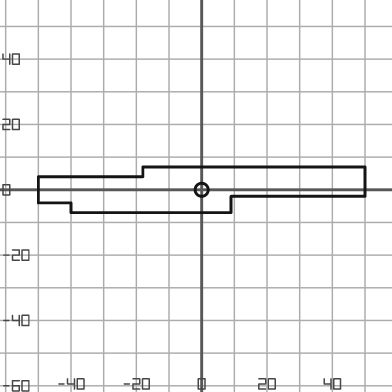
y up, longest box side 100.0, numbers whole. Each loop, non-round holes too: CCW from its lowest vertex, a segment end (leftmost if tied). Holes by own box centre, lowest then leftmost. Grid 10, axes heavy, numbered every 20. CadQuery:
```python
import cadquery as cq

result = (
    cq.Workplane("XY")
    .moveTo(-40.0, -7.0)
    .lineTo(9.0, -7.0)
    .lineTo(9.0, -2.0)
    .lineTo(50.0, -2.0)
    .lineTo(50.0, 7.0)
    .lineTo(-18.0, 7.0)
    .lineTo(-18.0, 4.0)
    .lineTo(-50.0, 4.0)
    .lineTo(-50.0, -4.0)
    .lineTo(-40.0, -4.0)
    .close()
    .moveTo(0.0, 0.0)
    .circle(2.0)
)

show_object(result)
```